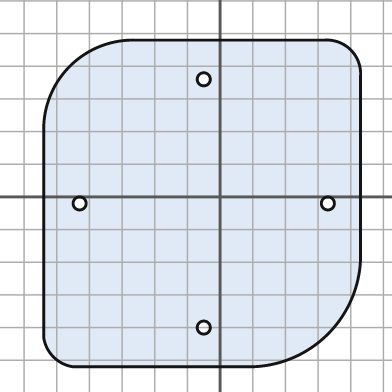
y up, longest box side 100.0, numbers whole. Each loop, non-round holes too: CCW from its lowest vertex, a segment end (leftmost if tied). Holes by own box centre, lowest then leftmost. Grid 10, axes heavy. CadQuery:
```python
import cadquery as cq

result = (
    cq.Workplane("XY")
    .moveTo(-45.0, -52.0)
    .lineTo(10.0, -52.0)
    .threePointArc((33.0, -42.0), (43.0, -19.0))
    .lineTo(43.0, 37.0)
    .threePointArc((40.0, 45.0), (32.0, 48.0))
    .lineTo(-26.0, 48.0)
    .threePointArc((-46.0, 40.0), (-54.0, 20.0))
    .lineTo(-54.0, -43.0)
    .threePointArc((-51.0, -49.0), (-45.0, -52.0))
    .close()
    .moveTo(-5.0, -40.0)
    .circle(2.0)
    .moveTo(-43.0, -2.0)
    .circle(2.0)
    .moveTo(33.0, -2.0)
    .circle(2.0)
    .moveTo(-5.0, 36.0)
    .circle(2.0)
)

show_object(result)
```